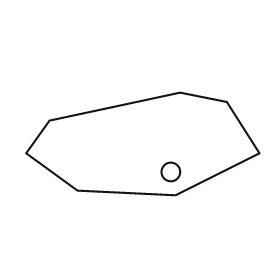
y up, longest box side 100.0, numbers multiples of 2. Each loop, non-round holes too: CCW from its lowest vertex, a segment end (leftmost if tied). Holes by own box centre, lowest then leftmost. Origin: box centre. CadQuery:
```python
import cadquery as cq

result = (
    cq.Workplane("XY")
    .moveTo(14.0, -22.0)
    .lineTo(50.0, -4.0)
    .lineTo(36.0, 18.0)
    .lineTo(16.0, 22.0)
    .lineTo(-40.0, 10.0)
    .lineTo(-50.0, -4.0)
    .lineTo(-28.0, -20.0)
    .close()
    .moveTo(12.0, -12.0)
    .circle(4.0)
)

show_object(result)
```